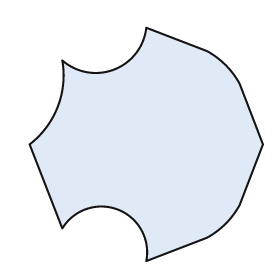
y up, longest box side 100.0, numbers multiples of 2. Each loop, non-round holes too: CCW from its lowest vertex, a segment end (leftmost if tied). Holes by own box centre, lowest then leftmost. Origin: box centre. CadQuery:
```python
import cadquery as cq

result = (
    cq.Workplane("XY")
    .moveTo(0.0, -50.0)
    .lineTo(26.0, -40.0)
    .threePointArc((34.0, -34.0), (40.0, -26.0))
    .lineTo(50.0, 0.0)
    .lineTo(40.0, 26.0)
    .threePointArc((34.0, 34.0), (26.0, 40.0))
    .lineTo(0.0, 50.0)
    .threePointArc((-14.0, 32.0), (-36.0, 36.0))
    .threePointArc((-38.0, 16.0), (-50.0, 0.0))
    .lineTo(-36.0, -36.0)
    .threePointArc((-12.0, -28.0), (0.0, -50.0))
    .close()
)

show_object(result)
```